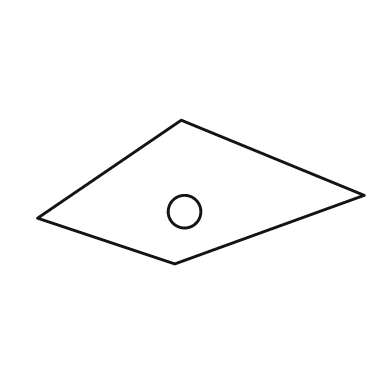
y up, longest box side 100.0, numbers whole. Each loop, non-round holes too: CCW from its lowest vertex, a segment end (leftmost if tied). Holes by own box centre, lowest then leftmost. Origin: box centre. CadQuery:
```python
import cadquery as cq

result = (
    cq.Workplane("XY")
    .moveTo(-8.0, -22.0)
    .lineTo(50.0, -1.0)
    .lineTo(-6.0, 22.0)
    .lineTo(-50.0, -8.0)
    .close()
    .moveTo(-5.0, -6.0)
    .circle(5.0)
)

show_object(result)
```